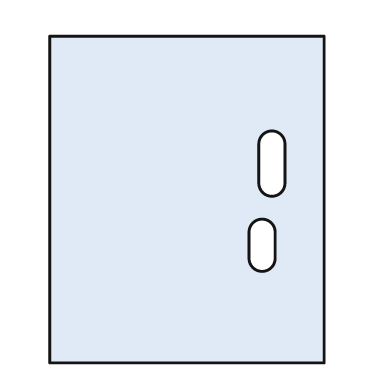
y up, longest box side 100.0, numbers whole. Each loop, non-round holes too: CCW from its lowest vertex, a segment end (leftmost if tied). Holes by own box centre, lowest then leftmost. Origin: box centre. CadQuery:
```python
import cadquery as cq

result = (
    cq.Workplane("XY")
    .moveTo(-42.0, -50.0)
    .lineTo(42.0, -50.0)
    .lineTo(42.0, 50.0)
    .lineTo(-42.0, 50.0)
    .close()
    .moveTo(19.0, -18.0)
    .threePointArc((23.0, -22.0), (27.0, -18.0))
    .lineTo(27.0, -10.0)
    .threePointArc((23.0, -6.0), (19.0, -10.0))
    .close()
    .moveTo(22.0, 5.0)
    .threePointArc((26.0, 1.0), (30.0, 5.0))
    .lineTo(30.0, 17.0)
    .threePointArc((26.0, 21.0), (22.0, 17.0))
    .close()
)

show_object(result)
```